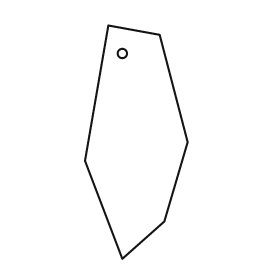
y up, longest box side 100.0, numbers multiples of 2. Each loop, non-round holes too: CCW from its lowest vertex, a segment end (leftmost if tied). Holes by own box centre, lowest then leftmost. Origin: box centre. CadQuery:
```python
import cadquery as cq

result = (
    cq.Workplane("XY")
    .moveTo(-6.0, -50.0)
    .lineTo(12.0, -34.0)
    .lineTo(22.0, 0.0)
    .lineTo(10.0, 46.0)
    .lineTo(-12.0, 50.0)
    .lineTo(-22.0, -8.0)
    .close()
    .moveTo(-6.0, 38.0)
    .circle(2.0)
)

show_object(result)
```